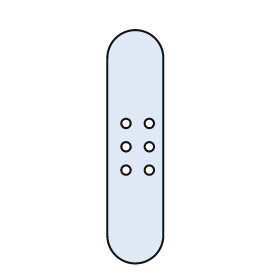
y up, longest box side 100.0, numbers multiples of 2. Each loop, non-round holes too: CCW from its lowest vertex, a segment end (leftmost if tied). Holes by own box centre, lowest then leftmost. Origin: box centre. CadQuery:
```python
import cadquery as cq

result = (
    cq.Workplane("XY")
    .moveTo(-12.0, -38.0)
    .threePointArc((0.0, -50.0), (12.0, -38.0))
    .lineTo(12.0, 38.0)
    .threePointArc((0.0, 50.0), (-12.0, 38.0))
    .close()
    .moveTo(-4.0, -10.0)
    .circle(2.0)
    .moveTo(6.0, -10.0)
    .circle(2.0)
    .moveTo(-4.0, 0.0)
    .circle(2.0)
    .moveTo(6.0, 0.0)
    .circle(2.0)
    .moveTo(-4.0, 10.0)
    .circle(2.0)
    .moveTo(6.0, 10.0)
    .circle(2.0)
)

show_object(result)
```